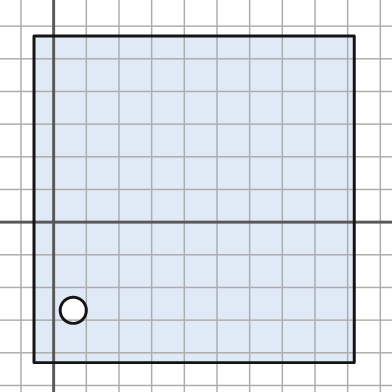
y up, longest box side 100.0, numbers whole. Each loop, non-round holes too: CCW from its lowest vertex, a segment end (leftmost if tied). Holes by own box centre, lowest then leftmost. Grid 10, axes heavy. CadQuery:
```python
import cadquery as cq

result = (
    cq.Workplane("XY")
    .moveTo(-6.0, -43.0)
    .lineTo(92.0, -43.0)
    .lineTo(92.0, 57.0)
    .lineTo(-6.0, 57.0)
    .close()
    .moveTo(6.0, -27.0)
    .circle(4.0)
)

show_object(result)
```